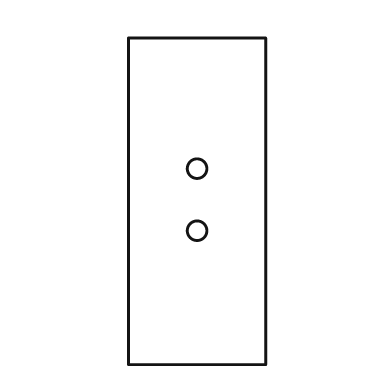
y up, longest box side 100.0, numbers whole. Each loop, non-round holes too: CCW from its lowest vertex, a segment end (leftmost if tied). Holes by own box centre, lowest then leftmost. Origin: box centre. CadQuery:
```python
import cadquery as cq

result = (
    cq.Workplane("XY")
    .moveTo(-21.0, -50.0)
    .lineTo(21.0, -50.0)
    .lineTo(21.0, 50.0)
    .lineTo(-21.0, 50.0)
    .close()
    .moveTo(0.0, -9.0)
    .circle(3.0)
    .moveTo(0.0, 10.0)
    .circle(3.0)
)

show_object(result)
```